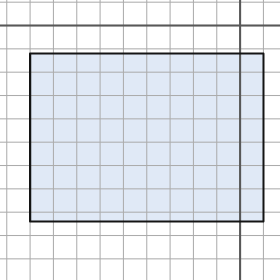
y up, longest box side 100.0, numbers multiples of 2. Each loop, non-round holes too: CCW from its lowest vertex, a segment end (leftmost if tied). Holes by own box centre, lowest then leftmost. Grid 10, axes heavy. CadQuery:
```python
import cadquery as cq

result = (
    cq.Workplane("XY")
    .moveTo(-90.0, -84.0)
    .lineTo(10.0, -84.0)
    .lineTo(10.0, -12.0)
    .lineTo(-90.0, -12.0)
    .close()
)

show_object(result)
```